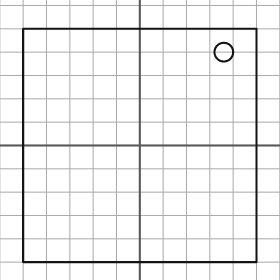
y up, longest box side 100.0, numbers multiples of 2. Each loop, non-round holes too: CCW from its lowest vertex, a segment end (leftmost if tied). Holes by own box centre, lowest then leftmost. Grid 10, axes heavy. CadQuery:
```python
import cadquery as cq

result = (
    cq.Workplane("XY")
    .moveTo(-50.0, -50.0)
    .lineTo(50.0, -50.0)
    .lineTo(50.0, 50.0)
    .lineTo(-50.0, 50.0)
    .close()
    .moveTo(36.0, 40.0)
    .circle(4.0)
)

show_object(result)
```